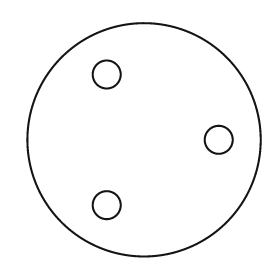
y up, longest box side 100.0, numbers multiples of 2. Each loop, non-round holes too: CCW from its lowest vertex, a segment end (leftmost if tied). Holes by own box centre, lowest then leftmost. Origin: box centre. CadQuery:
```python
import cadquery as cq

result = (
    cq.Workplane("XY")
    .moveTo(0.0, 0.0)
    .circle(50.0)
    .moveTo(-16.0, -28.0)
    .circle(6.0)
    .moveTo(32.0, 0.0)
    .circle(6.0)
    .moveTo(-16.0, 28.0)
    .circle(6.0)
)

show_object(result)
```